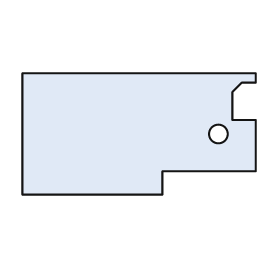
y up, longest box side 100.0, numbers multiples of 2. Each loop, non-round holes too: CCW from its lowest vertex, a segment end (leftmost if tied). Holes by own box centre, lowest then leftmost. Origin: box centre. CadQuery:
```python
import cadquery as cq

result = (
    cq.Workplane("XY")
    .moveTo(-50.0, -26.0)
    .lineTo(10.0, -26.0)
    .lineTo(10.0, -16.0)
    .lineTo(50.0, -16.0)
    .lineTo(50.0, 6.0)
    .lineTo(40.0, 6.0)
    .lineTo(40.0, 18.0)
    .lineTo(44.0, 22.0)
    .lineTo(50.0, 22.0)
    .lineTo(50.0, 26.0)
    .lineTo(-50.0, 26.0)
    .close()
    .moveTo(34.0, 0.0)
    .circle(4.0)
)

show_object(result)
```